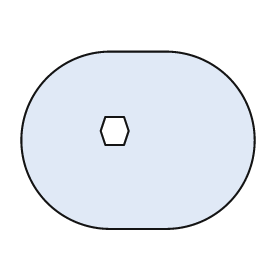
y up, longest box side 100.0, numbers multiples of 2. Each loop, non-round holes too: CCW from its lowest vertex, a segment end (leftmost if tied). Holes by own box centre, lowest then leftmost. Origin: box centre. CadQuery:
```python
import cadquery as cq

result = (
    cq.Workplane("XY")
    .moveTo(-12.0, -38.0)
    .lineTo(12.0, -38.0)
    .threePointArc((50.0, 0.0), (12.0, 38.0))
    .lineTo(-12.0, 38.0)
    .threePointArc((-50.0, 0.0), (-12.0, -38.0))
    .close()
    .moveTo(-14.0, -2.0)
    .lineTo(-6.0, -2.0)
    .lineTo(-4.0, 4.0)
    .lineTo(-6.0, 10.0)
    .lineTo(-14.0, 10.0)
    .lineTo(-16.0, 4.0)
    .close()
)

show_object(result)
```